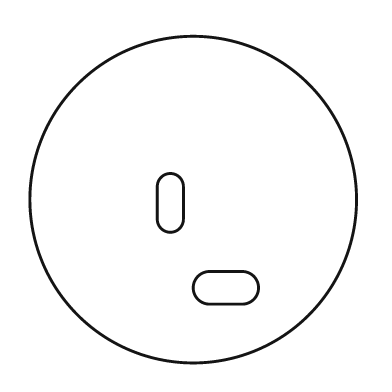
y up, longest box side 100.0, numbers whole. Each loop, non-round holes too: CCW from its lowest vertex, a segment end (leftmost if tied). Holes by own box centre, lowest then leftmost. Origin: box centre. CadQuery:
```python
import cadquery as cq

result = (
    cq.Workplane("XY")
    .moveTo(0.0, 0.0)
    .circle(50.0)
    .moveTo(5.0, -32.0)
    .lineTo(15.0, -32.0)
    .threePointArc((20.0, -27.0), (15.0, -22.0))
    .lineTo(5.0, -22.0)
    .threePointArc((0.0, -27.0), (5.0, -32.0))
    .close()
    .moveTo(-11.0, -6.0)
    .threePointArc((-7.0, -10.0), (-3.0, -6.0))
    .lineTo(-3.0, 4.0)
    .threePointArc((-7.0, 8.0), (-11.0, 4.0))
    .close()
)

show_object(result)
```